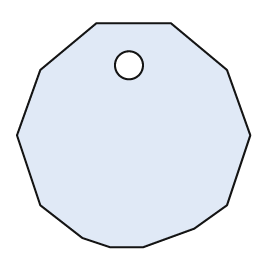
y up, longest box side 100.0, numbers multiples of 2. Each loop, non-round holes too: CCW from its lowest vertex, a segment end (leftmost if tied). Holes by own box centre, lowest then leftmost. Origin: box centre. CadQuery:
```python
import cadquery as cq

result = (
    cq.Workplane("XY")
    .moveTo(-10.0, -48.0)
    .lineTo(4.0, -48.0)
    .lineTo(26.0, -40.0)
    .lineTo(40.0, -30.0)
    .lineTo(50.0, 0.0)
    .lineTo(40.0, 28.0)
    .lineTo(16.0, 48.0)
    .lineTo(-16.0, 48.0)
    .lineTo(-40.0, 28.0)
    .lineTo(-50.0, 0.0)
    .lineTo(-40.0, -30.0)
    .lineTo(-22.0, -44.0)
    .close()
    .moveTo(-2.0, 30.0)
    .circle(6.0)
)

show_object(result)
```